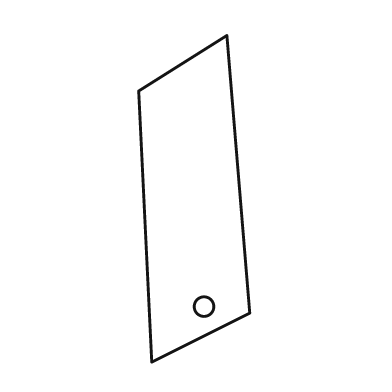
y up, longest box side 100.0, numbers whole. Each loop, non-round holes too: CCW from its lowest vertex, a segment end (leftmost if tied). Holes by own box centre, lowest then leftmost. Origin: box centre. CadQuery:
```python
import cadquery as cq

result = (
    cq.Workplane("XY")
    .moveTo(-13.0, -50.0)
    .lineTo(17.0, -35.0)
    .lineTo(10.0, 50.0)
    .lineTo(-17.0, 33.0)
    .close()
    .moveTo(3.0, -33.0)
    .circle(3.0)
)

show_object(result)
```